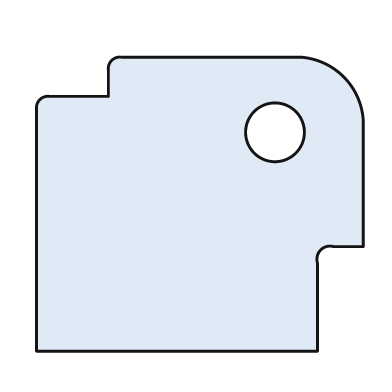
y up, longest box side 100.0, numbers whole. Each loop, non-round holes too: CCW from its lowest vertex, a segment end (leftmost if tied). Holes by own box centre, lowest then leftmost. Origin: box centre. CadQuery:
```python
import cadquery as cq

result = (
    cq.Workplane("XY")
    .moveTo(-50.0, -45.0)
    .lineTo(36.0, -45.0)
    .lineTo(36.0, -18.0)
    .threePointArc((37.0, -14.0), (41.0, -13.0))
    .lineTo(50.0, -13.0)
    .lineTo(50.0, 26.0)
    .threePointArc((44.0, 39.0), (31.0, 45.0))
    .lineTo(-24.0, 45.0)
    .threePointArc((-27.0, 44.0), (-28.0, 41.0))
    .lineTo(-28.0, 33.0)
    .lineTo(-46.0, 33.0)
    .threePointArc((-49.0, 32.0), (-50.0, 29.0))
    .close()
    .moveTo(23.0, 22.0)
    .circle(9.0)
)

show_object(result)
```